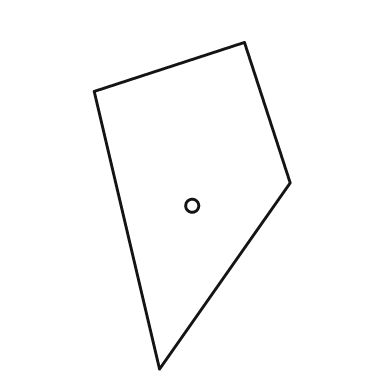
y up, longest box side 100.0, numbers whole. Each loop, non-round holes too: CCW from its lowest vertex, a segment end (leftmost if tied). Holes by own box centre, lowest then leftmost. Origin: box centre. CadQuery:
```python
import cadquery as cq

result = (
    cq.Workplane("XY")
    .moveTo(-10.0, -50.0)
    .lineTo(30.0, 7.0)
    .lineTo(16.0, 50.0)
    .lineTo(-30.0, 35.0)
    .close()
    .moveTo(0.0, 0.0)
    .circle(2.0)
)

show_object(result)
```